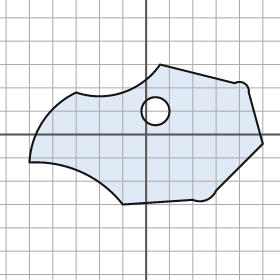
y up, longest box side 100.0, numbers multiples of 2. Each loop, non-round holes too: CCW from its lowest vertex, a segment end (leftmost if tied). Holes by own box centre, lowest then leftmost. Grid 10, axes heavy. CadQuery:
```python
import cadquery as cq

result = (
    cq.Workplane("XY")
    .moveTo(-10.0, -30.0)
    .lineTo(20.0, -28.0)
    .threePointArc((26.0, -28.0), (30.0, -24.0))
    .lineTo(50.0, -4.0)
    .lineTo(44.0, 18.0)
    .threePointArc((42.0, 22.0), (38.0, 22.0))
    .lineTo(6.0, 30.0)
    .threePointArc((-10.0, 18.0), (-30.0, 18.0))
    .threePointArc((-44.0, 6.0), (-50.0, -12.0))
    .threePointArc((-28.0, -16.0), (-10.0, -30.0))
    .close()
    .moveTo(4.0, 10.0)
    .circle(6.0)
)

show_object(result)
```